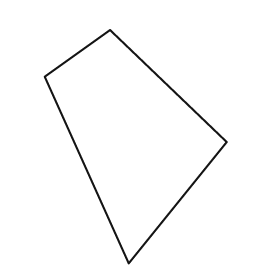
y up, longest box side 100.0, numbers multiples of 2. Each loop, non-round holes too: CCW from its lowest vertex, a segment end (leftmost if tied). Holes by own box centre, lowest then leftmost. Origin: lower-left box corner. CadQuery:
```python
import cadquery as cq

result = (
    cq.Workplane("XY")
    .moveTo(36.0, 0.0)
    .lineTo(78.0, 52.0)
    .lineTo(28.0, 100.0)
    .lineTo(0.0, 80.0)
    .close()
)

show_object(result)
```